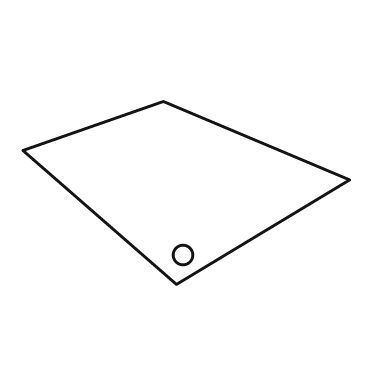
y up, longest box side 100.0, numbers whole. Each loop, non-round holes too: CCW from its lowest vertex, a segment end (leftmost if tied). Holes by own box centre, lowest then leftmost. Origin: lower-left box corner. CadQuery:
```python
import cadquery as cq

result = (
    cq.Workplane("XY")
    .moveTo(47.0, 0.0)
    .lineTo(100.0, 32.0)
    .lineTo(43.0, 56.0)
    .lineTo(0.0, 41.0)
    .close()
    .moveTo(49.0, 9.0)
    .circle(3.0)
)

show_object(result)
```